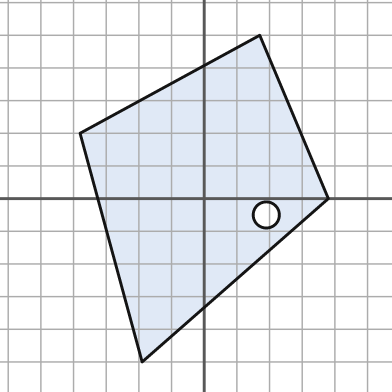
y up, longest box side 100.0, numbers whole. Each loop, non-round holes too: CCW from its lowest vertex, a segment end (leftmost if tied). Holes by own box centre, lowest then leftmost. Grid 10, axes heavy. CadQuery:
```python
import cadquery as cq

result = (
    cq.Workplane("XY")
    .moveTo(-19.0, -50.0)
    .lineTo(38.0, 0.0)
    .lineTo(17.0, 50.0)
    .lineTo(-38.0, 20.0)
    .close()
    .moveTo(19.0, -5.0)
    .circle(4.0)
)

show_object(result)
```